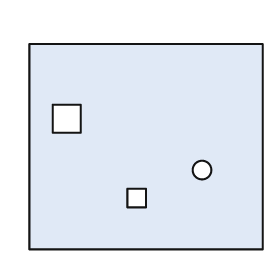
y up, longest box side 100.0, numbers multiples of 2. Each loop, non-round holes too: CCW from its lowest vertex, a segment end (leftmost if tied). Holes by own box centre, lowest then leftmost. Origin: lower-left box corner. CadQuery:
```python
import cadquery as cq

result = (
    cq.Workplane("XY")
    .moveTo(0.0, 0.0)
    .lineTo(100.0, 0.0)
    .lineTo(100.0, 88.0)
    .lineTo(0.0, 88.0)
    .close()
    .moveTo(42.0, 18.0)
    .lineTo(50.0, 18.0)
    .lineTo(50.0, 26.0)
    .lineTo(42.0, 26.0)
    .close()
    .moveTo(74.0, 34.0)
    .circle(4.0)
    .moveTo(10.0, 50.0)
    .lineTo(22.0, 50.0)
    .lineTo(22.0, 62.0)
    .lineTo(10.0, 62.0)
    .close()
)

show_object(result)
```